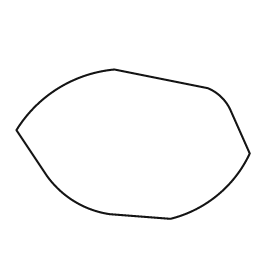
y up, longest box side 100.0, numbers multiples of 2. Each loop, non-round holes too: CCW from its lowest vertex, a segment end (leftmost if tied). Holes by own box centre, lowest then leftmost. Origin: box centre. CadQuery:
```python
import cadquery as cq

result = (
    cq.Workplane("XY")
    .moveTo(16.0, -32.0)
    .threePointArc((36.0, -22.0), (50.0, -4.0))
    .lineTo(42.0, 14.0)
    .threePointArc((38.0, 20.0), (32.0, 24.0))
    .lineTo(-8.0, 32.0)
    .threePointArc((-32.0, 24.0), (-50.0, 6.0))
    .lineTo(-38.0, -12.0)
    .threePointArc((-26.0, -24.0), (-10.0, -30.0))
    .close()
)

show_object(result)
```